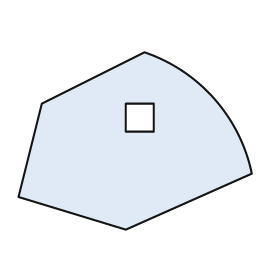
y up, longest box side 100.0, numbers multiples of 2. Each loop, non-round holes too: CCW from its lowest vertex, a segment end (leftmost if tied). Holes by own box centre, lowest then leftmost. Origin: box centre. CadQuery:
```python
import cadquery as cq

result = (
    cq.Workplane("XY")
    .moveTo(-4.0, -38.0)
    .lineTo(50.0, -14.0)
    .threePointArc((34.0, 18.0), (4.0, 38.0))
    .lineTo(-40.0, 16.0)
    .lineTo(-50.0, -24.0)
    .close()
    .moveTo(-4.0, 4.0)
    .lineTo(8.0, 4.0)
    .lineTo(8.0, 16.0)
    .lineTo(-4.0, 16.0)
    .close()
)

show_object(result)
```